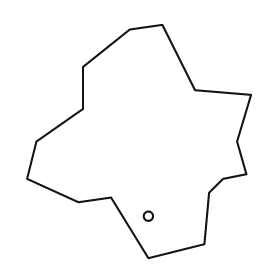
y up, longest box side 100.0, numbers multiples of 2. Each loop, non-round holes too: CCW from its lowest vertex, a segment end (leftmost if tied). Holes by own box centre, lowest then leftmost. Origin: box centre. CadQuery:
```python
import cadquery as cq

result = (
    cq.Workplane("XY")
    .moveTo(4.0, -50.0)
    .lineTo(28.0, -44.0)
    .lineTo(30.0, -22.0)
    .lineTo(36.0, -16.0)
    .lineTo(46.0, -14.0)
    .lineTo(42.0, 0.0)
    .lineTo(48.0, 20.0)
    .lineTo(24.0, 22.0)
    .lineTo(10.0, 50.0)
    .lineTo(-4.0, 48.0)
    .lineTo(-24.0, 32.0)
    .lineTo(-24.0, 14.0)
    .lineTo(-44.0, 0.0)
    .lineTo(-48.0, -16.0)
    .lineTo(-26.0, -26.0)
    .lineTo(-12.0, -24.0)
    .close()
    .moveTo(4.0, -32.0)
    .circle(2.0)
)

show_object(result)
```